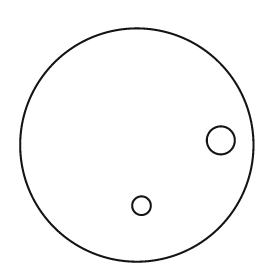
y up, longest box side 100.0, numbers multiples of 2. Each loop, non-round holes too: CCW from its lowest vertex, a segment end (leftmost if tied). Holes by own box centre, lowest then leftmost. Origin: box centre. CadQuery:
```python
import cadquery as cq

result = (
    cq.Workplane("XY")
    .moveTo(0.0, 0.0)
    .circle(50.0)
    .moveTo(2.0, -26.0)
    .circle(4.0)
    .moveTo(36.0, 2.0)
    .circle(6.0)
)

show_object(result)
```